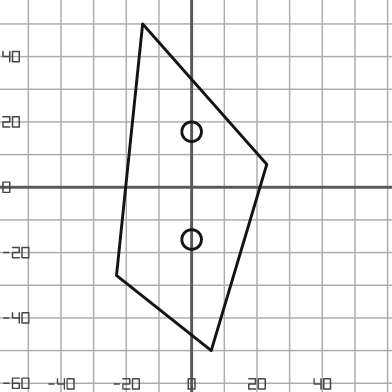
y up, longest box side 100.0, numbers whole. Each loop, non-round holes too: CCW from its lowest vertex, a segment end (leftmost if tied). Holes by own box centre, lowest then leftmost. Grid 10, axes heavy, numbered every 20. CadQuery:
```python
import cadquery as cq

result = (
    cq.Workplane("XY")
    .moveTo(6.0, -50.0)
    .lineTo(23.0, 7.0)
    .lineTo(-15.0, 50.0)
    .lineTo(-23.0, -27.0)
    .close()
    .moveTo(0.0, -16.0)
    .circle(3.0)
    .moveTo(0.0, 17.0)
    .circle(3.0)
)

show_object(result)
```